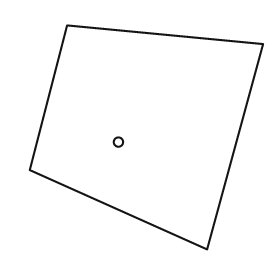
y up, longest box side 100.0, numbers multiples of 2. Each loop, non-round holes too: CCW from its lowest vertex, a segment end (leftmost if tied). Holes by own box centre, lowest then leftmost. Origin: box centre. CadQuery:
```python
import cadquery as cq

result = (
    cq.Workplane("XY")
    .moveTo(26.0, -48.0)
    .lineTo(50.0, 40.0)
    .lineTo(-34.0, 48.0)
    .lineTo(-50.0, -14.0)
    .close()
    .moveTo(-12.0, -2.0)
    .circle(2.0)
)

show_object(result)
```